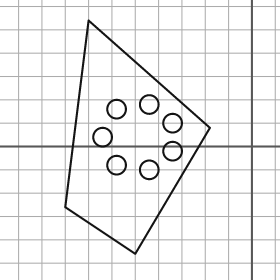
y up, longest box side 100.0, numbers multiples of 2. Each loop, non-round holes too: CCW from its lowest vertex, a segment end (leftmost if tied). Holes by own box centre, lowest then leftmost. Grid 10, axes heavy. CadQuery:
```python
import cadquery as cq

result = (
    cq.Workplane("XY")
    .moveTo(-50.0, -46.0)
    .lineTo(-18.0, 8.0)
    .lineTo(-70.0, 54.0)
    .lineTo(-80.0, -26.0)
    .close()
    .moveTo(-44.0, -10.0)
    .circle(4.0)
    .moveTo(-58.0, -8.0)
    .circle(4.0)
    .moveTo(-34.0, -2.0)
    .circle(4.0)
    .moveTo(-64.0, 4.0)
    .circle(4.0)
    .moveTo(-34.0, 10.0)
    .circle(4.0)
    .moveTo(-58.0, 16.0)
    .circle(4.0)
    .moveTo(-44.0, 18.0)
    .circle(4.0)
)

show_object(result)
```